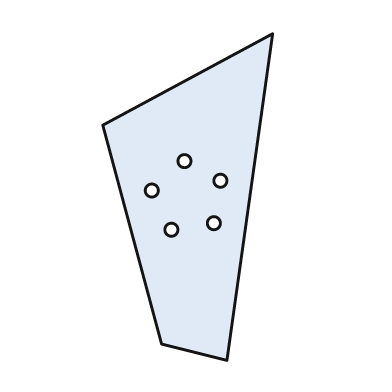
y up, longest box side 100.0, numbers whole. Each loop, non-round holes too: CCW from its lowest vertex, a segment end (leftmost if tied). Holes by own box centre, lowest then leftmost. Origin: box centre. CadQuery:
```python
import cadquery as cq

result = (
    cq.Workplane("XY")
    .moveTo(12.0, -50.0)
    .lineTo(26.0, 50.0)
    .lineTo(-26.0, 22.0)
    .lineTo(-8.0, -45.0)
    .close()
    .moveTo(-5.0, -10.0)
    .circle(2.0)
    .moveTo(8.0, -8.0)
    .circle(2.0)
    .moveTo(-11.0, 2.0)
    .circle(2.0)
    .moveTo(10.0, 5.0)
    .circle(2.0)
    .moveTo(-1.0, 11.0)
    .circle(2.0)
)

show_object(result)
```